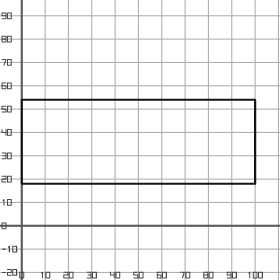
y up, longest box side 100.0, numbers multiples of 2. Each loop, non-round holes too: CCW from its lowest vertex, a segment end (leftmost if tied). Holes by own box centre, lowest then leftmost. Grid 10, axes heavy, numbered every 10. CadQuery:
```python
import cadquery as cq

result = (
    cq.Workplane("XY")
    .moveTo(0.0, 18.0)
    .lineTo(100.0, 18.0)
    .lineTo(100.0, 54.0)
    .lineTo(0.0, 54.0)
    .close()
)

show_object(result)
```